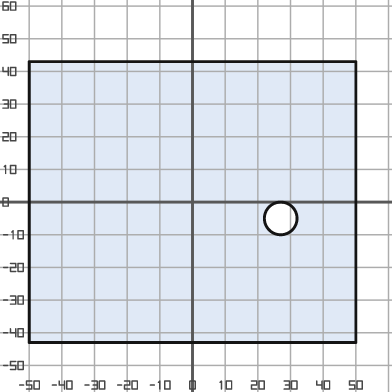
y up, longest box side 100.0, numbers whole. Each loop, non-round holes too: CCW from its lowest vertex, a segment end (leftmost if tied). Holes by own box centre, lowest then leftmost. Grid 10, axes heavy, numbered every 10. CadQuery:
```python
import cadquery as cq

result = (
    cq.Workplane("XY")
    .moveTo(-50.0, -43.0)
    .lineTo(50.0, -43.0)
    .lineTo(50.0, 43.0)
    .lineTo(-50.0, 43.0)
    .close()
    .moveTo(27.0, -5.0)
    .circle(5.0)
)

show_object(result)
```